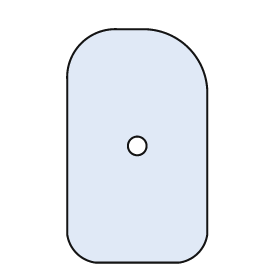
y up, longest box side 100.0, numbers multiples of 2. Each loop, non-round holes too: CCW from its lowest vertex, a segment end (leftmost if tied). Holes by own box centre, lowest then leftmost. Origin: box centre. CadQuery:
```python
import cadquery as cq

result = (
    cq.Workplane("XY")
    .moveTo(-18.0, -50.0)
    .lineTo(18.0, -50.0)
    .threePointArc((26.0, -46.0), (30.0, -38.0))
    .lineTo(30.0, 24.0)
    .threePointArc((22.0, 42.0), (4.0, 50.0))
    .lineTo(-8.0, 50.0)
    .threePointArc((-24.0, 44.0), (-30.0, 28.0))
    .lineTo(-30.0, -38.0)
    .threePointArc((-26.0, -46.0), (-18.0, -50.0))
    .close()
    .moveTo(0.0, 0.0)
    .circle(4.0)
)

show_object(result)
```